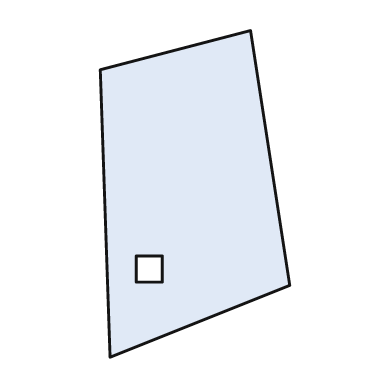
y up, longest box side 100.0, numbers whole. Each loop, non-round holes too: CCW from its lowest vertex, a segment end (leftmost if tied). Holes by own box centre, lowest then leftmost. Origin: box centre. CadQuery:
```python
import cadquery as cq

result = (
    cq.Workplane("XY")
    .moveTo(-26.0, -50.0)
    .lineTo(29.0, -28.0)
    .lineTo(17.0, 50.0)
    .lineTo(-29.0, 38.0)
    .close()
    .moveTo(-18.0, -27.0)
    .lineTo(-10.0, -27.0)
    .lineTo(-10.0, -19.0)
    .lineTo(-18.0, -19.0)
    .close()
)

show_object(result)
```